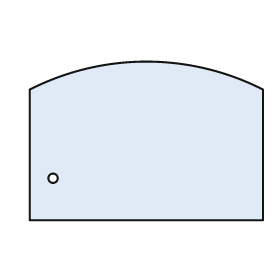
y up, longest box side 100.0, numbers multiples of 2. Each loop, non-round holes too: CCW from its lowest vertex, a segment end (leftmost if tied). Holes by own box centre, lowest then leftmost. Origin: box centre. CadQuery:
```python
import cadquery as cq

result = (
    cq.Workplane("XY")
    .moveTo(-50.0, -34.0)
    .lineTo(50.0, -34.0)
    .lineTo(50.0, 22.0)
    .threePointArc((0.0, 34.0), (-50.0, 22.0))
    .close()
    .moveTo(-40.0, -16.0)
    .circle(2.0)
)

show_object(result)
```